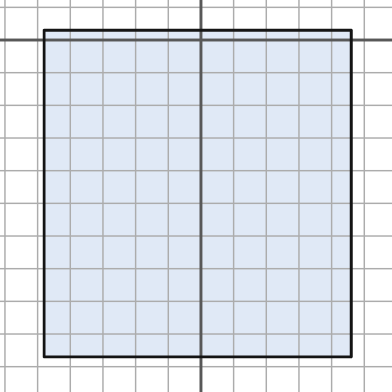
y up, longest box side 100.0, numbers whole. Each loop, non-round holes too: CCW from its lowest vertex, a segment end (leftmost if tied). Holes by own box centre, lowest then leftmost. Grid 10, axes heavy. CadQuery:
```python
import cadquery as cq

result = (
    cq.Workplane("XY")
    .moveTo(-48.0, -97.0)
    .lineTo(46.0, -97.0)
    .lineTo(46.0, 3.0)
    .lineTo(-48.0, 3.0)
    .close()
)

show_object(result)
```